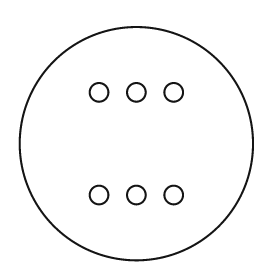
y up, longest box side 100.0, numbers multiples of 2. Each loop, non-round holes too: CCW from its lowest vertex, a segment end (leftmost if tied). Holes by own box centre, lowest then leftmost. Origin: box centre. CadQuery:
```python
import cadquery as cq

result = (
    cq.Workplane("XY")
    .moveTo(0.0, 0.0)
    .circle(50.0)
    .moveTo(-16.0, -22.0)
    .circle(4.0)
    .moveTo(0.0, -22.0)
    .circle(4.0)
    .moveTo(16.0, -22.0)
    .circle(4.0)
    .moveTo(-16.0, 22.0)
    .circle(4.0)
    .moveTo(0.0, 22.0)
    .circle(4.0)
    .moveTo(16.0, 22.0)
    .circle(4.0)
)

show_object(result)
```